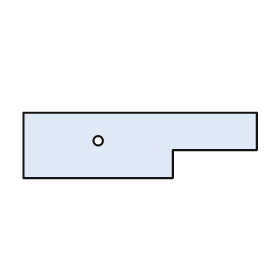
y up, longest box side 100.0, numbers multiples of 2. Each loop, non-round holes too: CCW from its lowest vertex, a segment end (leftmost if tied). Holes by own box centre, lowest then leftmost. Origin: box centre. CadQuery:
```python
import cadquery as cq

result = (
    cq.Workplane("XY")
    .moveTo(-50.0, -14.0)
    .lineTo(14.0, -14.0)
    .lineTo(14.0, -2.0)
    .lineTo(50.0, -2.0)
    .lineTo(50.0, 14.0)
    .lineTo(-50.0, 14.0)
    .close()
    .moveTo(-18.0, 2.0)
    .circle(2.0)
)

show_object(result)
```